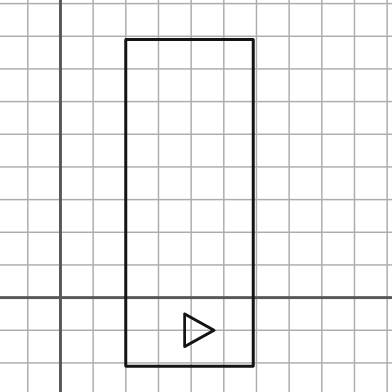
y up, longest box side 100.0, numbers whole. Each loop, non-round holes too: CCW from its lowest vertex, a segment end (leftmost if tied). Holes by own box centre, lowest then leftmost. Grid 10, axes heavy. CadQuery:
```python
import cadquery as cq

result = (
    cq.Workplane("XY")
    .moveTo(20.0, -21.0)
    .lineTo(59.0, -21.0)
    .lineTo(59.0, 79.0)
    .lineTo(20.0, 79.0)
    .close()
    .moveTo(38.0, -15.0)
    .lineTo(47.0, -10.0)
    .lineTo(38.0, -5.0)
    .close()
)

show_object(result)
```